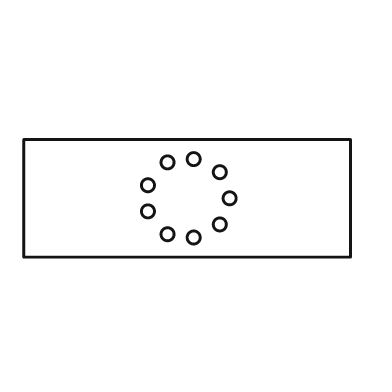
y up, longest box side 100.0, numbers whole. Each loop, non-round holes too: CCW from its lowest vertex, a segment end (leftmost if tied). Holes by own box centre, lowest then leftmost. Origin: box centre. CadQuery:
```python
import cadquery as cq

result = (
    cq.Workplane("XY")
    .moveTo(-50.0, -18.0)
    .lineTo(50.0, -18.0)
    .lineTo(50.0, 18.0)
    .lineTo(-50.0, 18.0)
    .close()
    .moveTo(2.0, -12.0)
    .circle(2.0)
    .moveTo(-6.0, -11.0)
    .circle(2.0)
    .moveTo(10.0, -8.0)
    .circle(2.0)
    .moveTo(-12.0, -4.0)
    .circle(2.0)
    .moveTo(13.0, 0.0)
    .circle(2.0)
    .moveTo(-12.0, 4.0)
    .circle(2.0)
    .moveTo(10.0, 8.0)
    .circle(2.0)
    .moveTo(-6.0, 11.0)
    .circle(2.0)
    .moveTo(2.0, 12.0)
    .circle(2.0)
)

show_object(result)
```